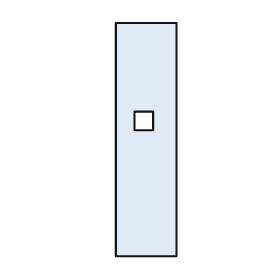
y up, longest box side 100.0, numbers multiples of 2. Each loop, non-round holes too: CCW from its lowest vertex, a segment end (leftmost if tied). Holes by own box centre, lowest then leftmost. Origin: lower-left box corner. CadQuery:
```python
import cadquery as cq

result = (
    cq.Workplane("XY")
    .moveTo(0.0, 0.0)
    .lineTo(26.0, 0.0)
    .lineTo(26.0, 100.0)
    .lineTo(0.0, 100.0)
    .close()
    .moveTo(8.0, 54.0)
    .lineTo(16.0, 54.0)
    .lineTo(16.0, 62.0)
    .lineTo(8.0, 62.0)
    .close()
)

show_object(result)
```